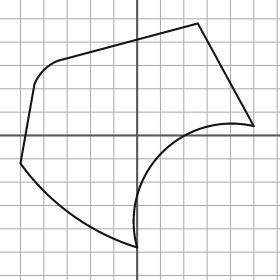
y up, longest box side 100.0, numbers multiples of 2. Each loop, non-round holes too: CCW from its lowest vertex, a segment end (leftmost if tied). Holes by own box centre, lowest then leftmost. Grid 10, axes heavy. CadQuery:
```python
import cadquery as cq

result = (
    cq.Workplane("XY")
    .moveTo(0.0, -48.0)
    .threePointArc((10.0, -8.0), (50.0, 4.0))
    .lineTo(26.0, 48.0)
    .lineTo(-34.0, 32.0)
    .threePointArc((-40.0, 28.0), (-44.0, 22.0))
    .lineTo(-50.0, -12.0)
    .threePointArc((-28.0, -34.0), (0.0, -48.0))
    .close()
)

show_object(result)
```